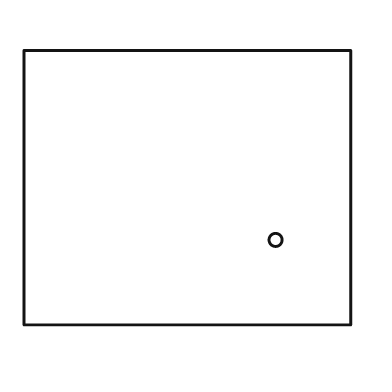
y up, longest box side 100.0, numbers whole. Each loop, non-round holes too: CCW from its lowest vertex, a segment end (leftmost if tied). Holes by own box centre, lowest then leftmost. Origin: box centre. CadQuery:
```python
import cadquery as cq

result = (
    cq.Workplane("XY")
    .moveTo(-50.0, -42.0)
    .lineTo(50.0, -42.0)
    .lineTo(50.0, 42.0)
    .lineTo(-50.0, 42.0)
    .close()
    .moveTo(27.0, -16.0)
    .circle(2.0)
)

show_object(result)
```